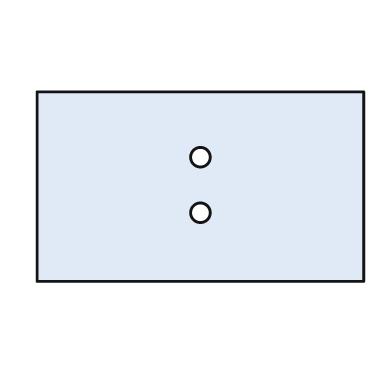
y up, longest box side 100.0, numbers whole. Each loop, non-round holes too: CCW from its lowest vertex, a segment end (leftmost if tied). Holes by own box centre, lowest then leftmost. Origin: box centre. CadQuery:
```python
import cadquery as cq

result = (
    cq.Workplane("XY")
    .moveTo(-50.0, -29.0)
    .lineTo(50.0, -29.0)
    .lineTo(50.0, 29.0)
    .lineTo(-50.0, 29.0)
    .close()
    .moveTo(0.0, -8.0)
    .circle(3.0)
    .moveTo(0.0, 9.0)
    .circle(3.0)
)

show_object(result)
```